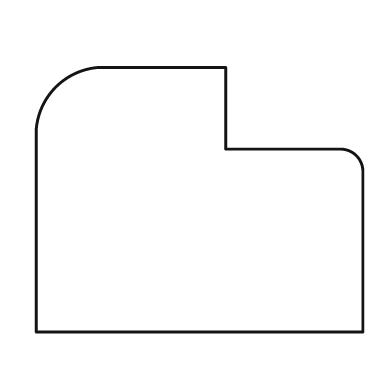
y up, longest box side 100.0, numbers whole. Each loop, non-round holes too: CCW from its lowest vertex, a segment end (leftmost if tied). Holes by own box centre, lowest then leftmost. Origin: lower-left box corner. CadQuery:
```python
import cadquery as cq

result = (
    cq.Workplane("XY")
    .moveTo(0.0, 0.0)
    .lineTo(100.0, 0.0)
    .lineTo(100.0, 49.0)
    .threePointArc((98.0, 54.0), (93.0, 56.0))
    .lineTo(58.0, 56.0)
    .lineTo(58.0, 81.0)
    .lineTo(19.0, 81.0)
    .threePointArc((6.0, 75.0), (0.0, 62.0))
    .close()
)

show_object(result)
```